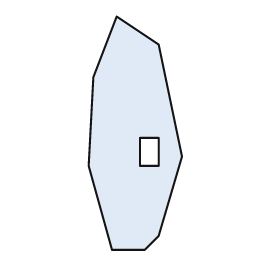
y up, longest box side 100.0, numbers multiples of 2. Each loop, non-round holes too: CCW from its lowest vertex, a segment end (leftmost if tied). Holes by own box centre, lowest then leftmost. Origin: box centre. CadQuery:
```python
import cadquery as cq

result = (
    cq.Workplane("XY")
    .moveTo(-10.0, -50.0)
    .lineTo(4.0, -50.0)
    .lineTo(10.0, -44.0)
    .lineTo(20.0, -10.0)
    .lineTo(10.0, 38.0)
    .lineTo(-8.0, 50.0)
    .lineTo(-18.0, 24.0)
    .lineTo(-20.0, -14.0)
    .close()
    .moveTo(2.0, -14.0)
    .lineTo(10.0, -14.0)
    .lineTo(10.0, -2.0)
    .lineTo(2.0, -2.0)
    .close()
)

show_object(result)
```